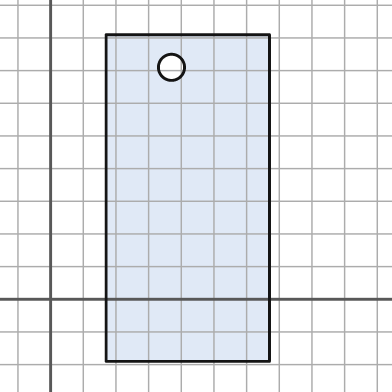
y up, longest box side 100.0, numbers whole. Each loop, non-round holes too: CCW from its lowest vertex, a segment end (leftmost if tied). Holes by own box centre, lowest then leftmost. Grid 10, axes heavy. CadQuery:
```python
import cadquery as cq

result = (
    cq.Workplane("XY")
    .moveTo(17.0, -19.0)
    .lineTo(67.0, -19.0)
    .lineTo(67.0, 81.0)
    .lineTo(17.0, 81.0)
    .close()
    .moveTo(37.0, 71.0)
    .circle(4.0)
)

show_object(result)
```